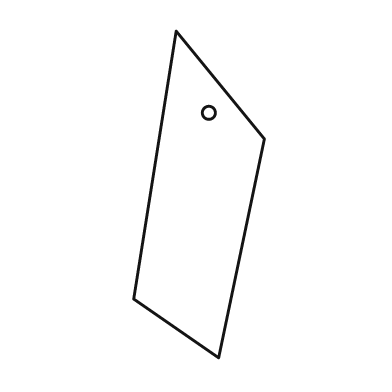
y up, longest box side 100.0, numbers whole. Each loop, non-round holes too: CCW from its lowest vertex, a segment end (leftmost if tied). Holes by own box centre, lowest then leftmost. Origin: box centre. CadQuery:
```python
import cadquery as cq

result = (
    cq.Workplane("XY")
    .moveTo(6.0, -50.0)
    .lineTo(20.0, 17.0)
    .lineTo(-7.0, 50.0)
    .lineTo(-20.0, -32.0)
    .close()
    .moveTo(3.0, 25.0)
    .circle(2.0)
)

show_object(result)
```